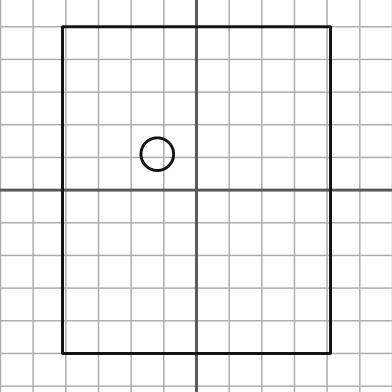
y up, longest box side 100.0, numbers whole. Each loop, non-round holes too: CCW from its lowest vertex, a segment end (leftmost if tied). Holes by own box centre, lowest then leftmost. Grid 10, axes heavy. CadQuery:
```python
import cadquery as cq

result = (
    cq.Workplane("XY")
    .moveTo(-41.0, -50.0)
    .lineTo(41.0, -50.0)
    .lineTo(41.0, 50.0)
    .lineTo(-41.0, 50.0)
    .close()
    .moveTo(-12.0, 11.0)
    .circle(5.0)
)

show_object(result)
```